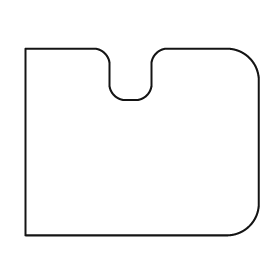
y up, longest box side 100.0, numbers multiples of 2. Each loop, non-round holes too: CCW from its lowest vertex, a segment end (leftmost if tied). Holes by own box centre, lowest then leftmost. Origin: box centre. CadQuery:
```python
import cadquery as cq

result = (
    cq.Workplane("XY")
    .moveTo(-50.0, -40.0)
    .lineTo(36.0, -40.0)
    .threePointArc((46.0, -36.0), (50.0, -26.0))
    .lineTo(50.0, 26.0)
    .threePointArc((46.0, 36.0), (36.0, 40.0))
    .lineTo(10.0, 40.0)
    .threePointArc((6.0, 38.0), (4.0, 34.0))
    .lineTo(4.0, 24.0)
    .threePointArc((2.0, 20.0), (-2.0, 18.0))
    .lineTo(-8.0, 18.0)
    .threePointArc((-12.0, 20.0), (-14.0, 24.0))
    .lineTo(-14.0, 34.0)
    .threePointArc((-16.0, 38.0), (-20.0, 40.0))
    .lineTo(-50.0, 40.0)
    .close()
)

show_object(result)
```